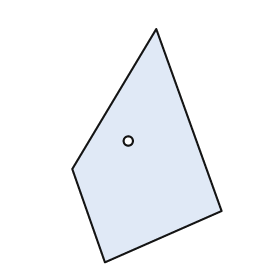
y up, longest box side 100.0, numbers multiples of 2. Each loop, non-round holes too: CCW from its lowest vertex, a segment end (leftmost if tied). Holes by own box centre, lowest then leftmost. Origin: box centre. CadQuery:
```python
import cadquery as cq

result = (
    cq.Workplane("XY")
    .moveTo(-18.0, -50.0)
    .lineTo(32.0, -28.0)
    .lineTo(4.0, 50.0)
    .lineTo(-32.0, -10.0)
    .close()
    .moveTo(-8.0, 2.0)
    .circle(2.0)
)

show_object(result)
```